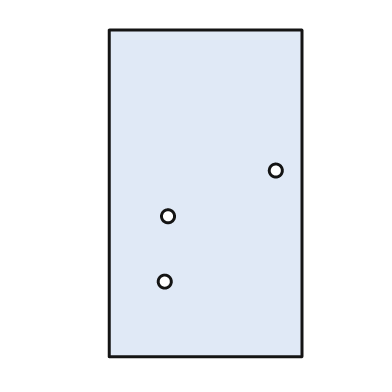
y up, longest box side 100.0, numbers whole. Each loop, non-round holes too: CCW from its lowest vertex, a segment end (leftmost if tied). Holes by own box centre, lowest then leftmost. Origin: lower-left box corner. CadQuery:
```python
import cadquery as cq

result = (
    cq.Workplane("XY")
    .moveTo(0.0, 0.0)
    .lineTo(59.0, 0.0)
    .lineTo(59.0, 100.0)
    .lineTo(0.0, 100.0)
    .close()
    .moveTo(17.0, 23.0)
    .circle(2.0)
    .moveTo(18.0, 43.0)
    .circle(2.0)
    .moveTo(51.0, 57.0)
    .circle(2.0)
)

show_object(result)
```